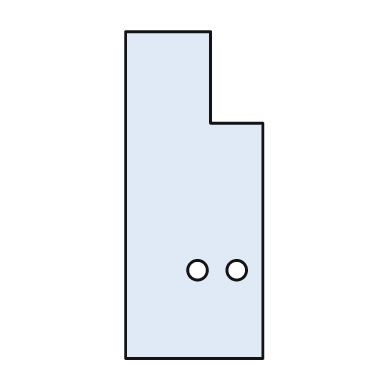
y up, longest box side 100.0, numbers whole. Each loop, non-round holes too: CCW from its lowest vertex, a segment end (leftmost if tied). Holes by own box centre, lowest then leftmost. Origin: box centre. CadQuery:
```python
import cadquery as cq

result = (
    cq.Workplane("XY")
    .moveTo(-21.0, -50.0)
    .lineTo(21.0, -50.0)
    .lineTo(21.0, 22.0)
    .lineTo(5.0, 22.0)
    .lineTo(5.0, 50.0)
    .lineTo(-21.0, 50.0)
    .close()
    .moveTo(1.0, -23.0)
    .circle(3.0)
    .moveTo(13.0, -23.0)
    .circle(3.0)
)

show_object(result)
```